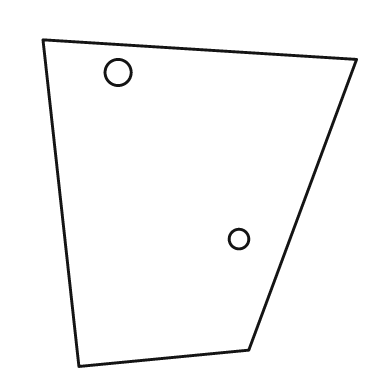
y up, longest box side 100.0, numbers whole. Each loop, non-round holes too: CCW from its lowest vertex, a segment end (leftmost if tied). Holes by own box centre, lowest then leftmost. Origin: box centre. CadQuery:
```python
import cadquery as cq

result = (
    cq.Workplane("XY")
    .moveTo(-37.0, -50.0)
    .lineTo(15.0, -45.0)
    .lineTo(48.0, 44.0)
    .lineTo(-48.0, 50.0)
    .close()
    .moveTo(12.0, -11.0)
    .circle(3.0)
    .moveTo(-25.0, 40.0)
    .circle(4.0)
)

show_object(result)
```